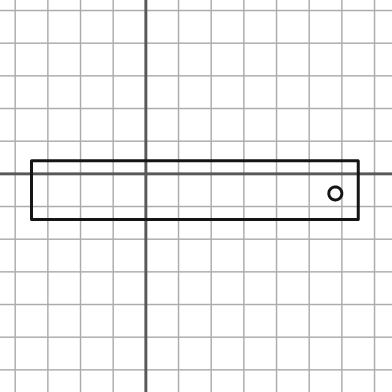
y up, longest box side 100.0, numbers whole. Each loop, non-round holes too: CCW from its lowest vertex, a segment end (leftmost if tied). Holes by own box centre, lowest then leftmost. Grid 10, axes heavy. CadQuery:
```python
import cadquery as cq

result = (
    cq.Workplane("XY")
    .moveTo(-35.0, -14.0)
    .lineTo(65.0, -14.0)
    .lineTo(65.0, 4.0)
    .lineTo(-35.0, 4.0)
    .close()
    .moveTo(58.0, -6.0)
    .circle(2.0)
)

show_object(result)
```